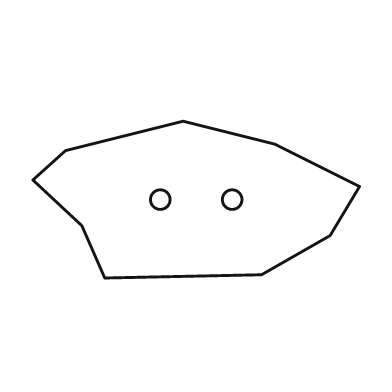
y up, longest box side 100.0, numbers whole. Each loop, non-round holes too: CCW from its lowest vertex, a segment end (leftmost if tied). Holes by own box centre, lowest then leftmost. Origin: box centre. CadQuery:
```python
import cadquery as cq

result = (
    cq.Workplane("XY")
    .moveTo(-28.0, -24.0)
    .lineTo(20.0, -23.0)
    .lineTo(41.0, -11.0)
    .lineTo(50.0, 4.0)
    .lineTo(24.0, 17.0)
    .lineTo(-4.0, 24.0)
    .lineTo(-40.0, 15.0)
    .lineTo(-50.0, 6.0)
    .lineTo(-35.0, -8.0)
    .close()
    .moveTo(-11.0, 0.0)
    .circle(3.0)
    .moveTo(11.0, 0.0)
    .circle(3.0)
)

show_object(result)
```